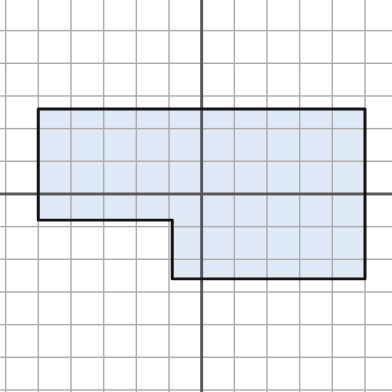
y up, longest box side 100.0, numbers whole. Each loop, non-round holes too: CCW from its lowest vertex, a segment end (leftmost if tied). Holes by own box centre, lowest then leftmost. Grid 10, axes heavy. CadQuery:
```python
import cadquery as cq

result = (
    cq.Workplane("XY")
    .moveTo(-9.0, -26.0)
    .lineTo(50.0, -26.0)
    .lineTo(50.0, 26.0)
    .lineTo(-50.0, 26.0)
    .lineTo(-50.0, -8.0)
    .lineTo(-9.0, -8.0)
    .close()
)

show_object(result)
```